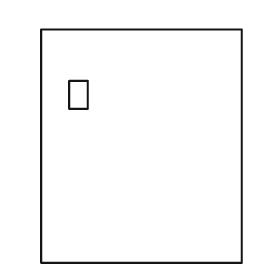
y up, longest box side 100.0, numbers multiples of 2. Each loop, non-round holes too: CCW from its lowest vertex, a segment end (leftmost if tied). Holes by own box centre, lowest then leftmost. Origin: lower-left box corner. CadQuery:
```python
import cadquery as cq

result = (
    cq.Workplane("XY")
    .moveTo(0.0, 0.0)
    .lineTo(86.0, 0.0)
    .lineTo(86.0, 100.0)
    .lineTo(0.0, 100.0)
    .close()
    .moveTo(12.0, 66.0)
    .lineTo(20.0, 66.0)
    .lineTo(20.0, 78.0)
    .lineTo(12.0, 78.0)
    .close()
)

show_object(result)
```